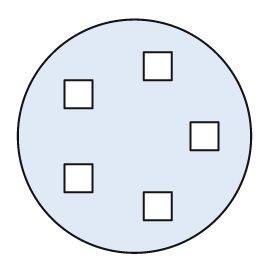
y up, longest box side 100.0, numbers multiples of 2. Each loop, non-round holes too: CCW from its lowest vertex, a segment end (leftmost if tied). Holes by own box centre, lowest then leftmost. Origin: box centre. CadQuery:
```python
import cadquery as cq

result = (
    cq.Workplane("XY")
    .moveTo(0.0, 0.0)
    .circle(50.0)
    .moveTo(4.0, -36.0)
    .lineTo(16.0, -36.0)
    .lineTo(16.0, -24.0)
    .lineTo(4.0, -24.0)
    .close()
    .moveTo(-30.0, -24.0)
    .lineTo(-18.0, -24.0)
    .lineTo(-18.0, -12.0)
    .lineTo(-30.0, -12.0)
    .close()
    .moveTo(24.0, -6.0)
    .lineTo(36.0, -6.0)
    .lineTo(36.0, 6.0)
    .lineTo(24.0, 6.0)
    .close()
    .moveTo(-30.0, 12.0)
    .lineTo(-18.0, 12.0)
    .lineTo(-18.0, 24.0)
    .lineTo(-30.0, 24.0)
    .close()
    .moveTo(4.0, 24.0)
    .lineTo(16.0, 24.0)
    .lineTo(16.0, 36.0)
    .lineTo(4.0, 36.0)
    .close()
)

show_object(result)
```